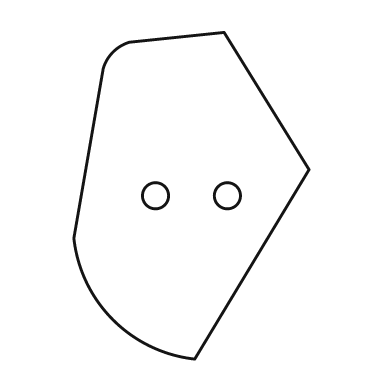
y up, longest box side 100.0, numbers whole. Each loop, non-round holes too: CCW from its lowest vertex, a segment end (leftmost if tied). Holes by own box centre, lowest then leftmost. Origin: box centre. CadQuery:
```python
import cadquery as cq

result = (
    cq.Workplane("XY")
    .moveTo(1.0, -50.0)
    .lineTo(36.0, 8.0)
    .lineTo(10.0, 50.0)
    .lineTo(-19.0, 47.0)
    .threePointArc((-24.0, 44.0), (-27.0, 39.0))
    .lineTo(-36.0, -13.0)
    .threePointArc((-24.0, -38.0), (1.0, -50.0))
    .close()
    .moveTo(-11.0, 0.0)
    .circle(4.0)
    .moveTo(11.0, 0.0)
    .circle(4.0)
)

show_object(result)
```